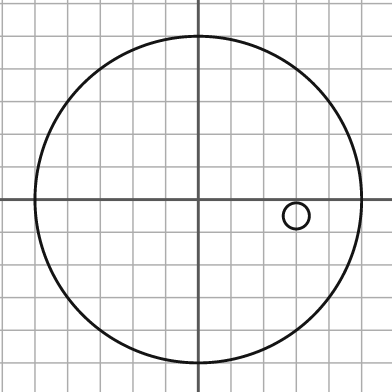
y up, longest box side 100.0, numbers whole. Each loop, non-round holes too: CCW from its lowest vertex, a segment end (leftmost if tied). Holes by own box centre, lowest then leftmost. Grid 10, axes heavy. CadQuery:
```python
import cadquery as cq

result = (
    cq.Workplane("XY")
    .moveTo(0.0, 0.0)
    .circle(50.0)
    .moveTo(30.0, -5.0)
    .circle(4.0)
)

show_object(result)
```